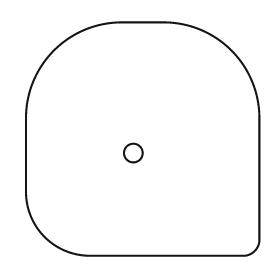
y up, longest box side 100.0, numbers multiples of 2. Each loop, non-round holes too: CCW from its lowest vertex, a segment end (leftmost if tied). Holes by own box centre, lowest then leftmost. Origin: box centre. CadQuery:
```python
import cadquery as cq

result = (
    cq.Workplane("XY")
    .moveTo(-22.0, -50.0)
    .lineTo(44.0, -50.0)
    .threePointArc((48.0, -48.0), (50.0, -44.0))
    .lineTo(50.0, 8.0)
    .threePointArc((38.0, 38.0), (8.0, 50.0))
    .lineTo(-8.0, 50.0)
    .threePointArc((-38.0, 38.0), (-50.0, 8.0))
    .lineTo(-50.0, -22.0)
    .threePointArc((-42.0, -42.0), (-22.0, -50.0))
    .close()
    .moveTo(-4.0, -6.0)
    .circle(4.0)
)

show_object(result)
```